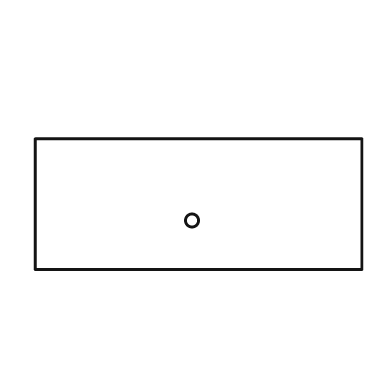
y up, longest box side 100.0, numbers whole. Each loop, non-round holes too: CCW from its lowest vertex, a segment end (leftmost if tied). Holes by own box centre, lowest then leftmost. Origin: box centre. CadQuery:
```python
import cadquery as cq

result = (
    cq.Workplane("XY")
    .moveTo(-50.0, -20.0)
    .lineTo(50.0, -20.0)
    .lineTo(50.0, 20.0)
    .lineTo(-50.0, 20.0)
    .close()
    .moveTo(-2.0, -5.0)
    .circle(2.0)
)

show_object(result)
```